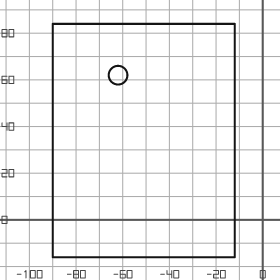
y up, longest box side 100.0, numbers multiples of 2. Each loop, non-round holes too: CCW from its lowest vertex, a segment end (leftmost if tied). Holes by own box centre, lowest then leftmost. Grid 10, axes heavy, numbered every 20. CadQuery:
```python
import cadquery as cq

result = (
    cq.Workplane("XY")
    .moveTo(-90.0, -16.0)
    .lineTo(-12.0, -16.0)
    .lineTo(-12.0, 84.0)
    .lineTo(-90.0, 84.0)
    .close()
    .moveTo(-62.0, 62.0)
    .circle(4.0)
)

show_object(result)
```